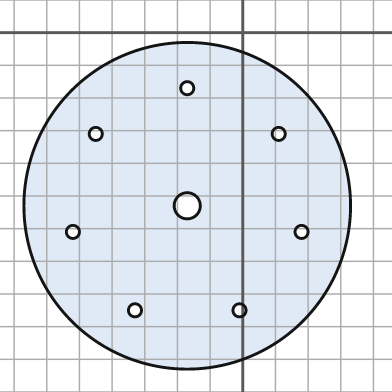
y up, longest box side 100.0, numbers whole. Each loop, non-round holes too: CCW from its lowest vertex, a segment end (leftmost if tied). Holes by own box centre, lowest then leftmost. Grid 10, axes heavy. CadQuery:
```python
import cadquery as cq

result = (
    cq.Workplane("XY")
    .moveTo(-17.0, -53.0)
    .circle(50.0)
    .moveTo(-33.0, -85.0)
    .circle(2.0)
    .moveTo(-1.0, -85.0)
    .circle(2.0)
    .moveTo(-52.0, -61.0)
    .circle(2.0)
    .moveTo(18.0, -61.0)
    .circle(2.0)
    .moveTo(-17.0, -53.0)
    .circle(4.0)
    .moveTo(-45.0, -31.0)
    .circle(2.0)
    .moveTo(11.0, -31.0)
    .circle(2.0)
    .moveTo(-17.0, -17.0)
    .circle(2.0)
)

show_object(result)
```